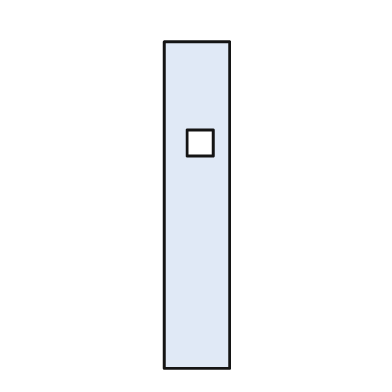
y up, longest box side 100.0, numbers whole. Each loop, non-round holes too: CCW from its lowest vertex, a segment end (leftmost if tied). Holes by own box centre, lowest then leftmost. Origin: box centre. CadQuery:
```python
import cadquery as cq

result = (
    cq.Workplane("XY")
    .moveTo(-10.0, -50.0)
    .lineTo(10.0, -50.0)
    .lineTo(10.0, 50.0)
    .lineTo(-10.0, 50.0)
    .close()
    .moveTo(-3.0, 15.0)
    .lineTo(5.0, 15.0)
    .lineTo(5.0, 23.0)
    .lineTo(-3.0, 23.0)
    .close()
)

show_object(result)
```